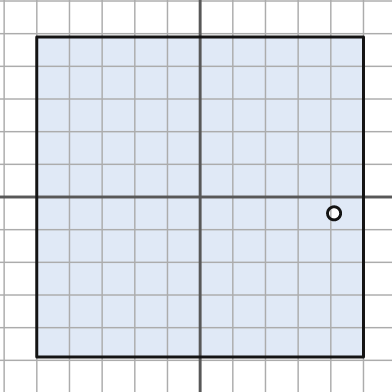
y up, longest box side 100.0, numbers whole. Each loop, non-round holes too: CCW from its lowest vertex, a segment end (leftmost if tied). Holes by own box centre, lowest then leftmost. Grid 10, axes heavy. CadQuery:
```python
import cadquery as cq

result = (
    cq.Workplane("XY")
    .moveTo(-50.0, -49.0)
    .lineTo(50.0, -49.0)
    .lineTo(50.0, 49.0)
    .lineTo(-50.0, 49.0)
    .close()
    .moveTo(41.0, -5.0)
    .circle(2.0)
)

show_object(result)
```